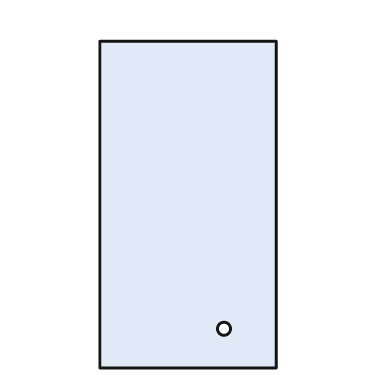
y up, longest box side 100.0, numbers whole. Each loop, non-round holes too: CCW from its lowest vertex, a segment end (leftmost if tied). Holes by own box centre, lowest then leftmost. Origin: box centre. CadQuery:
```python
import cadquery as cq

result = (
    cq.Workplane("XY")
    .moveTo(-27.0, -50.0)
    .lineTo(27.0, -50.0)
    .lineTo(27.0, 50.0)
    .lineTo(-27.0, 50.0)
    .close()
    .moveTo(11.0, -38.0)
    .circle(2.0)
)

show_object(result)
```